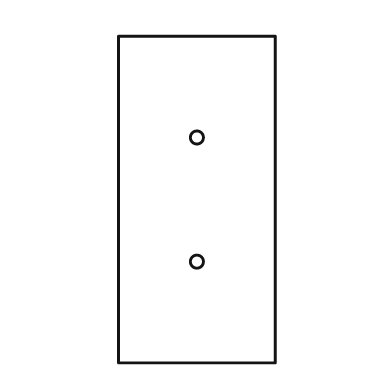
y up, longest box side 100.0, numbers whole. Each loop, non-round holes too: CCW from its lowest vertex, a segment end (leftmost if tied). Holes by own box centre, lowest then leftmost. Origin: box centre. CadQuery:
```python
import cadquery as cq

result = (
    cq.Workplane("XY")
    .moveTo(-24.0, -50.0)
    .lineTo(24.0, -50.0)
    .lineTo(24.0, 50.0)
    .lineTo(-24.0, 50.0)
    .close()
    .moveTo(0.0, -19.0)
    .circle(2.0)
    .moveTo(0.0, 19.0)
    .circle(2.0)
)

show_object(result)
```